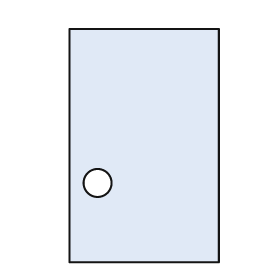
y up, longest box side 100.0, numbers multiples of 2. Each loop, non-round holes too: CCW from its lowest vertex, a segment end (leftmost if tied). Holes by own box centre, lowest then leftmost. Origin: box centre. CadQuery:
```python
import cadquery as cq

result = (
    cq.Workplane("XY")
    .moveTo(-32.0, -50.0)
    .lineTo(32.0, -50.0)
    .lineTo(32.0, 50.0)
    .lineTo(-32.0, 50.0)
    .close()
    .moveTo(-20.0, -16.0)
    .circle(6.0)
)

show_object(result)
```